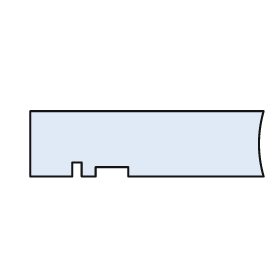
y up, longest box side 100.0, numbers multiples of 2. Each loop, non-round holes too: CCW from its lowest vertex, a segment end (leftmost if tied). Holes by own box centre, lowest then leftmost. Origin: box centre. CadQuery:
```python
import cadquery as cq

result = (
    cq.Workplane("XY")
    .moveTo(-50.0, -14.0)
    .lineTo(-32.0, -14.0)
    .lineTo(-32.0, -8.0)
    .lineTo(-28.0, -8.0)
    .lineTo(-28.0, -14.0)
    .lineTo(-22.0, -14.0)
    .lineTo(-22.0, -10.0)
    .lineTo(-8.0, -10.0)
    .lineTo(-8.0, -14.0)
    .lineTo(50.0, -14.0)
    .threePointArc((48.0, 0.0), (50.0, 14.0))
    .lineTo(-50.0, 14.0)
    .close()
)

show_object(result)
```